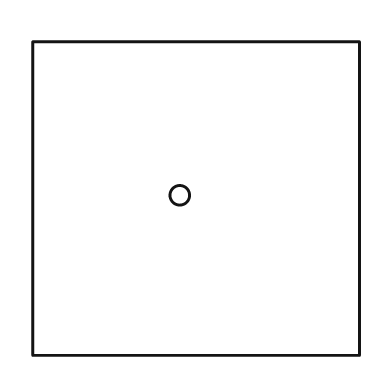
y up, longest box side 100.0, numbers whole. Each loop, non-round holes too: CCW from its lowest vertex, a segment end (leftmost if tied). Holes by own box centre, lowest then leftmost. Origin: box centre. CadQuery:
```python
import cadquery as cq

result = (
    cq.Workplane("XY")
    .moveTo(-50.0, -48.0)
    .lineTo(50.0, -48.0)
    .lineTo(50.0, 48.0)
    .lineTo(-50.0, 48.0)
    .close()
    .moveTo(-5.0, 1.0)
    .circle(3.0)
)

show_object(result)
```